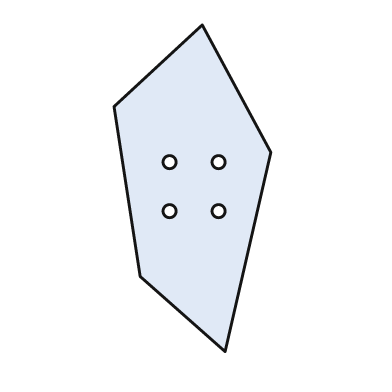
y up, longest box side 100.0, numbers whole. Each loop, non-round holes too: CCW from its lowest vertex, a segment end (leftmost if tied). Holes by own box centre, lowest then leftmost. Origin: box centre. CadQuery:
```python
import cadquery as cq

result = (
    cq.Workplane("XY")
    .moveTo(10.0, -50.0)
    .lineTo(24.0, 11.0)
    .lineTo(3.0, 50.0)
    .lineTo(-24.0, 25.0)
    .lineTo(-16.0, -27.0)
    .close()
    .moveTo(-7.0, -7.0)
    .circle(2.0)
    .moveTo(8.0, -7.0)
    .circle(2.0)
    .moveTo(-7.0, 8.0)
    .circle(2.0)
    .moveTo(8.0, 8.0)
    .circle(2.0)
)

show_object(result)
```